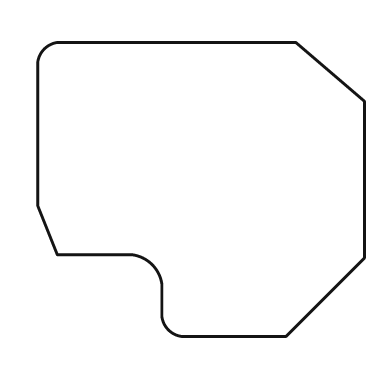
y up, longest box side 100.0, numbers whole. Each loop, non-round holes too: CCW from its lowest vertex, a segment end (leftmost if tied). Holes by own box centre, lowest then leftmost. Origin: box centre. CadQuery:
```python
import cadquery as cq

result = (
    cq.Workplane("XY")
    .moveTo(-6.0, -45.0)
    .lineTo(26.0, -45.0)
    .lineTo(50.0, -21.0)
    .lineTo(50.0, 27.0)
    .lineTo(29.0, 45.0)
    .lineTo(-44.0, 45.0)
    .threePointArc((-48.0, 43.0), (-50.0, 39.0))
    .lineTo(-50.0, -5.0)
    .lineTo(-44.0, -20.0)
    .lineTo(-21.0, -20.0)
    .threePointArc((-15.0, -23.0), (-12.0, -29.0))
    .lineTo(-12.0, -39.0)
    .threePointArc((-10.0, -43.0), (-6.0, -45.0))
    .close()
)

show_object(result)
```